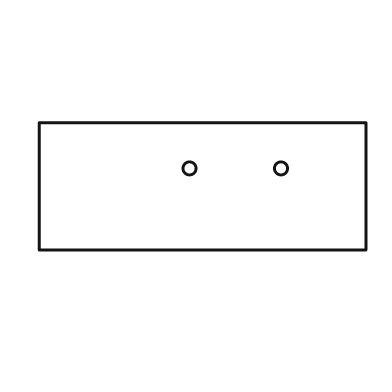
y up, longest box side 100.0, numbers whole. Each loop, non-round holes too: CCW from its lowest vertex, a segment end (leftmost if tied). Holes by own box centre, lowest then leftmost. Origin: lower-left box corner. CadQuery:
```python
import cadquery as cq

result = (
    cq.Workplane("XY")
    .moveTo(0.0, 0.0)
    .lineTo(100.0, 0.0)
    .lineTo(100.0, 39.0)
    .lineTo(0.0, 39.0)
    .close()
    .moveTo(46.0, 25.0)
    .circle(2.0)
    .moveTo(74.0, 25.0)
    .circle(2.0)
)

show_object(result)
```